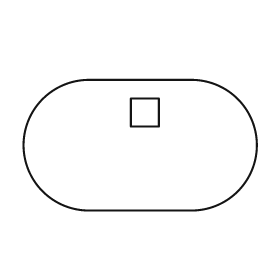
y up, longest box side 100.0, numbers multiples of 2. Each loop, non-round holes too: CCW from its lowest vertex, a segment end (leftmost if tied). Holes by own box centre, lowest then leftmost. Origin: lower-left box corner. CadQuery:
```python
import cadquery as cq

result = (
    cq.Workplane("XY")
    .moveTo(28.0, 0.0)
    .lineTo(72.0, 0.0)
    .threePointArc((100.0, 28.0), (72.0, 56.0))
    .lineTo(28.0, 56.0)
    .threePointArc((0.0, 28.0), (28.0, 0.0))
    .close()
    .moveTo(46.0, 36.0)
    .lineTo(58.0, 36.0)
    .lineTo(58.0, 48.0)
    .lineTo(46.0, 48.0)
    .close()
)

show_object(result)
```